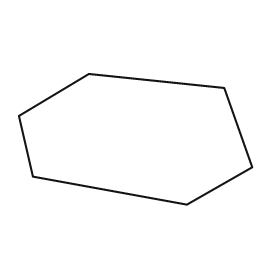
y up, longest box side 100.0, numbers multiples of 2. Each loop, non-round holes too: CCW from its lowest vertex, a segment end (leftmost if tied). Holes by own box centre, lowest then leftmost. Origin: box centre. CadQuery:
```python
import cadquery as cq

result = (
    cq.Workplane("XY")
    .moveTo(22.0, -28.0)
    .lineTo(50.0, -12.0)
    .lineTo(38.0, 22.0)
    .lineTo(-20.0, 28.0)
    .lineTo(-50.0, 10.0)
    .lineTo(-44.0, -16.0)
    .close()
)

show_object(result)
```